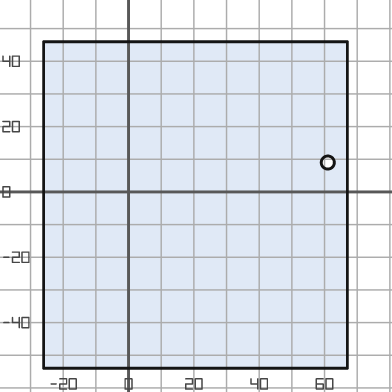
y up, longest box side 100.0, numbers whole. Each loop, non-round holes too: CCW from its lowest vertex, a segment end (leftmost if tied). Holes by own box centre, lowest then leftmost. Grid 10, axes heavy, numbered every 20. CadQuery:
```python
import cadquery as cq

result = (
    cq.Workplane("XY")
    .moveTo(-26.0, -54.0)
    .lineTo(67.0, -54.0)
    .lineTo(67.0, 46.0)
    .lineTo(-26.0, 46.0)
    .close()
    .moveTo(61.0, 9.0)
    .circle(2.0)
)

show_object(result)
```